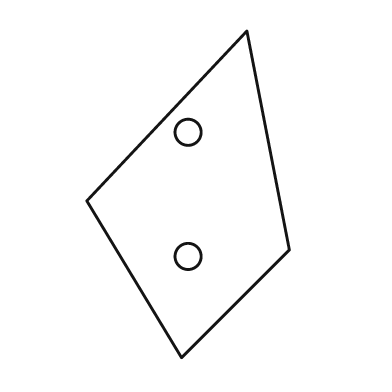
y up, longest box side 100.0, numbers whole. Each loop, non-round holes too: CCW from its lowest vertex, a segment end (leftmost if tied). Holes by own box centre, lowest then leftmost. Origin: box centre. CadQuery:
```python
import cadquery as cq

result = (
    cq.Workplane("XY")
    .moveTo(-2.0, -50.0)
    .lineTo(31.0, -17.0)
    .lineTo(18.0, 50.0)
    .lineTo(-31.0, -2.0)
    .close()
    .moveTo(0.0, -19.0)
    .circle(4.0)
    .moveTo(0.0, 19.0)
    .circle(4.0)
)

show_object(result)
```